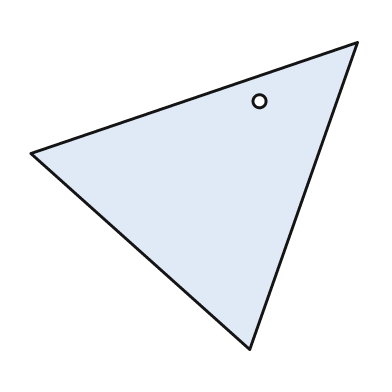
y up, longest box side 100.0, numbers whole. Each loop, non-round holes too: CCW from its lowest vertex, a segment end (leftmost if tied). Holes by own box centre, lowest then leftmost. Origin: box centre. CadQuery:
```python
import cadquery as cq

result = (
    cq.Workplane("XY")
    .moveTo(17.0, -47.0)
    .lineTo(50.0, 47.0)
    .lineTo(-50.0, 13.0)
    .close()
    .moveTo(20.0, 29.0)
    .circle(2.0)
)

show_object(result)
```